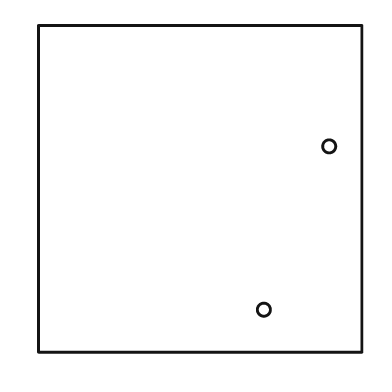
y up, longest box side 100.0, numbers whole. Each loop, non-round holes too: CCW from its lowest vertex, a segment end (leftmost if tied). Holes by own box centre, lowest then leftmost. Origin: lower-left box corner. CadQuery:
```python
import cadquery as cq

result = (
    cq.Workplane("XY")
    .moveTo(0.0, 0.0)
    .lineTo(99.0, 0.0)
    .lineTo(99.0, 100.0)
    .lineTo(0.0, 100.0)
    .close()
    .moveTo(69.0, 13.0)
    .circle(2.0)
    .moveTo(89.0, 63.0)
    .circle(2.0)
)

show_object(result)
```